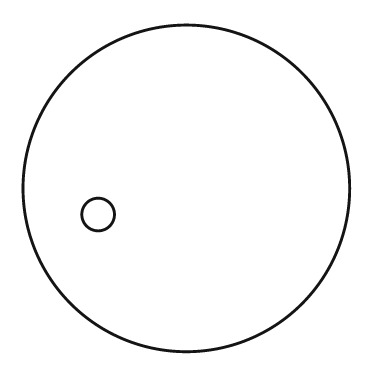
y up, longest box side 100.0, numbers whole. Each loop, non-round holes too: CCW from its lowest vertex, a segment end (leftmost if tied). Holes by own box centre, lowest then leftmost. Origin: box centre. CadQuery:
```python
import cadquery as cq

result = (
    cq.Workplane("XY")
    .moveTo(0.0, 0.0)
    .circle(50.0)
    .moveTo(-27.0, -8.0)
    .circle(5.0)
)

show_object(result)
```